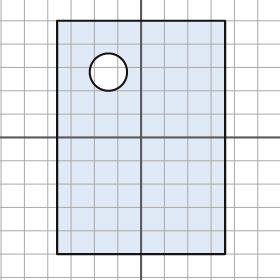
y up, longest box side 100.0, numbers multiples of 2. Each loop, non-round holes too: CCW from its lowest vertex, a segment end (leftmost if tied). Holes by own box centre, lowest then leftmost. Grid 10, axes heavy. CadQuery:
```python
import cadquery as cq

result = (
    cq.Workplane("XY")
    .moveTo(-36.0, -50.0)
    .lineTo(36.0, -50.0)
    .lineTo(36.0, 50.0)
    .lineTo(-36.0, 50.0)
    .close()
    .moveTo(-14.0, 28.0)
    .circle(8.0)
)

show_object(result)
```